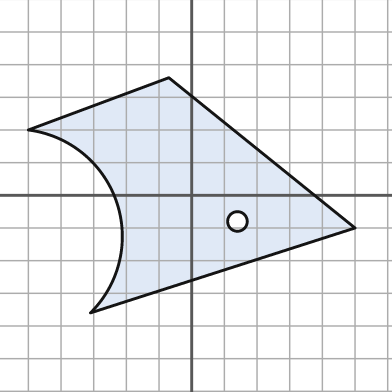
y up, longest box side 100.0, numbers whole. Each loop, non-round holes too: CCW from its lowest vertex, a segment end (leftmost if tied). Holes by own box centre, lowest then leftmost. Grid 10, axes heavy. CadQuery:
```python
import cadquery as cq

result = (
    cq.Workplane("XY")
    .moveTo(-31.0, -36.0)
    .lineTo(50.0, -10.0)
    .lineTo(-7.0, 36.0)
    .lineTo(-50.0, 20.0)
    .threePointArc((-23.0, -2.0), (-31.0, -36.0))
    .close()
    .moveTo(14.0, -8.0)
    .circle(3.0)
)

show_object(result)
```